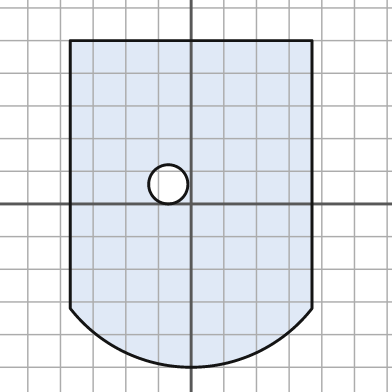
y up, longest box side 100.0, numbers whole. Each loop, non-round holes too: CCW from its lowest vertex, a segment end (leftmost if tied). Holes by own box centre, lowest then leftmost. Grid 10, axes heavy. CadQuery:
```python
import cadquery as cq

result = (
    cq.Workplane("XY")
    .moveTo(-37.0, -32.0)
    .threePointArc((0.0, -50.0), (37.0, -32.0))
    .lineTo(37.0, 50.0)
    .lineTo(-37.0, 50.0)
    .close()
    .moveTo(-7.0, 6.0)
    .circle(6.0)
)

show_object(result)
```